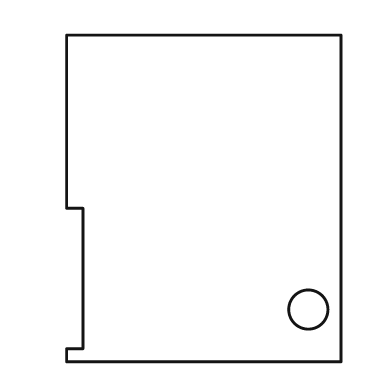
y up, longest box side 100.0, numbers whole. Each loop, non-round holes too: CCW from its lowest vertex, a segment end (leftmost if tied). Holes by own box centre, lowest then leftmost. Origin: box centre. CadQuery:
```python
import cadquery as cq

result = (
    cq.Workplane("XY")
    .moveTo(-42.0, -50.0)
    .lineTo(42.0, -50.0)
    .lineTo(42.0, 50.0)
    .lineTo(-42.0, 50.0)
    .lineTo(-42.0, -3.0)
    .lineTo(-37.0, -3.0)
    .lineTo(-37.0, -46.0)
    .lineTo(-42.0, -46.0)
    .close()
    .moveTo(32.0, -34.0)
    .circle(6.0)
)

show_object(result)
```